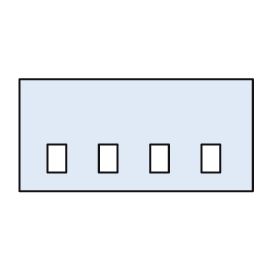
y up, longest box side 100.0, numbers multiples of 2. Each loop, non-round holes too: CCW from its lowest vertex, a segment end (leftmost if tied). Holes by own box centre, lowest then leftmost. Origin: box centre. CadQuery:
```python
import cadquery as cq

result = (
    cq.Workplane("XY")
    .moveTo(-50.0, -24.0)
    .lineTo(50.0, -24.0)
    .lineTo(50.0, 24.0)
    .lineTo(-50.0, 24.0)
    .close()
    .moveTo(-38.0, -16.0)
    .lineTo(-30.0, -16.0)
    .lineTo(-30.0, -4.0)
    .lineTo(-38.0, -4.0)
    .close()
    .moveTo(-16.0, -16.0)
    .lineTo(-8.0, -16.0)
    .lineTo(-8.0, -4.0)
    .lineTo(-16.0, -4.0)
    .close()
    .moveTo(6.0, -16.0)
    .lineTo(14.0, -16.0)
    .lineTo(14.0, -4.0)
    .lineTo(6.0, -4.0)
    .close()
    .moveTo(28.0, -16.0)
    .lineTo(36.0, -16.0)
    .lineTo(36.0, -4.0)
    .lineTo(28.0, -4.0)
    .close()
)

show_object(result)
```